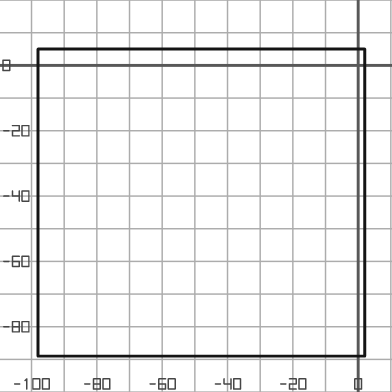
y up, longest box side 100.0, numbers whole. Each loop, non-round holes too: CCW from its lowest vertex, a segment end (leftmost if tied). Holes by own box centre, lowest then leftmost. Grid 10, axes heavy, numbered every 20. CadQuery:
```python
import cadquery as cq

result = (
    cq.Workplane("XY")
    .moveTo(-98.0, -89.0)
    .lineTo(2.0, -89.0)
    .lineTo(2.0, 5.0)
    .lineTo(-98.0, 5.0)
    .close()
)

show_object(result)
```